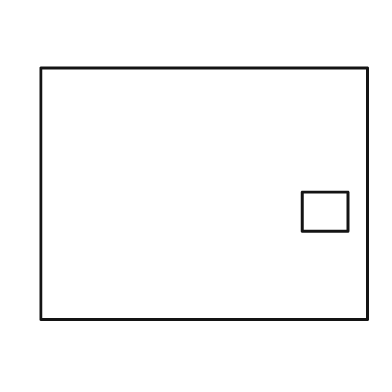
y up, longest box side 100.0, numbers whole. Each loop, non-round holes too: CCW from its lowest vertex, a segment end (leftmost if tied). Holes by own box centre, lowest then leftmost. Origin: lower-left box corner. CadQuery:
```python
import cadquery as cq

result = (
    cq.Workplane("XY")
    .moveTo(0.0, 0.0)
    .lineTo(100.0, 0.0)
    .lineTo(100.0, 77.0)
    .lineTo(0.0, 77.0)
    .close()
    .moveTo(80.0, 27.0)
    .lineTo(94.0, 27.0)
    .lineTo(94.0, 39.0)
    .lineTo(80.0, 39.0)
    .close()
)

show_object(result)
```